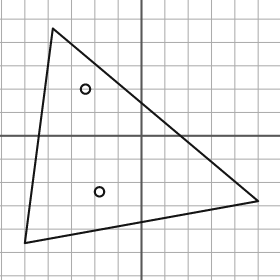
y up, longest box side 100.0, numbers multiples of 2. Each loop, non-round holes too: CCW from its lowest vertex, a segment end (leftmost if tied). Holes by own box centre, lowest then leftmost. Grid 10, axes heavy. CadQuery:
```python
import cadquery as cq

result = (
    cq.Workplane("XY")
    .moveTo(-50.0, -46.0)
    .lineTo(50.0, -28.0)
    .lineTo(-38.0, 46.0)
    .close()
    .moveTo(-18.0, -24.0)
    .circle(2.0)
    .moveTo(-24.0, 20.0)
    .circle(2.0)
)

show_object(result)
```